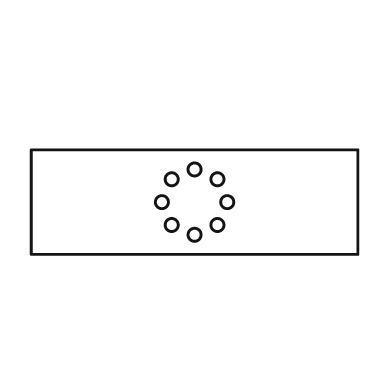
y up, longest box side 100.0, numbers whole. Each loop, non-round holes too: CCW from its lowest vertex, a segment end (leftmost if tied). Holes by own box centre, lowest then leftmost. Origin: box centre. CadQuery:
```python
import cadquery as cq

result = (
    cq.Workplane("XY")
    .moveTo(-50.0, -16.0)
    .lineTo(50.0, -16.0)
    .lineTo(50.0, 16.0)
    .lineTo(-50.0, 16.0)
    .close()
    .moveTo(0.0, -10.0)
    .circle(2.0)
    .moveTo(-7.0, -7.0)
    .circle(2.0)
    .moveTo(7.0, -7.0)
    .circle(2.0)
    .moveTo(-10.0, 0.0)
    .circle(2.0)
    .moveTo(10.0, 0.0)
    .circle(2.0)
    .moveTo(-7.0, 7.0)
    .circle(2.0)
    .moveTo(7.0, 7.0)
    .circle(2.0)
    .moveTo(0.0, 10.0)
    .circle(2.0)
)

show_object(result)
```